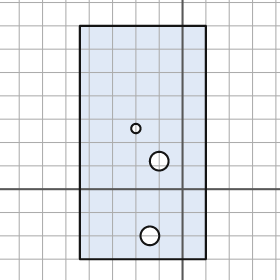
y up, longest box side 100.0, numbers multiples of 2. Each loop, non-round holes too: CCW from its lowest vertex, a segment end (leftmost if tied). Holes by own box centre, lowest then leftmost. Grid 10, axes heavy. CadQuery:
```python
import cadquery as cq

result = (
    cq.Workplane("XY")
    .moveTo(-44.0, -30.0)
    .lineTo(10.0, -30.0)
    .lineTo(10.0, 70.0)
    .lineTo(-44.0, 70.0)
    .close()
    .moveTo(-14.0, -20.0)
    .circle(4.0)
    .moveTo(-10.0, 12.0)
    .circle(4.0)
    .moveTo(-20.0, 26.0)
    .circle(2.0)
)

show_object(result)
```